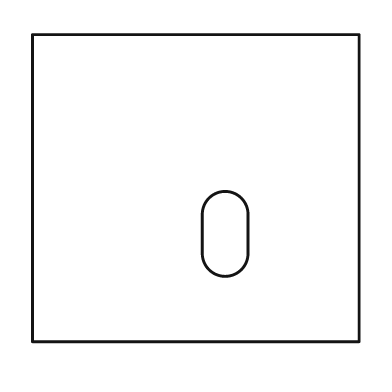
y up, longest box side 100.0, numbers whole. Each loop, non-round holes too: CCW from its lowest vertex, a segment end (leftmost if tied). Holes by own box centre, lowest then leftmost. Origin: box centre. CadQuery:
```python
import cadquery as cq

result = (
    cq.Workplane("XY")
    .moveTo(-50.0, -47.0)
    .lineTo(50.0, -47.0)
    .lineTo(50.0, 47.0)
    .lineTo(-50.0, 47.0)
    .close()
    .moveTo(2.0, -20.0)
    .threePointArc((9.0, -27.0), (16.0, -20.0))
    .lineTo(16.0, -8.0)
    .threePointArc((9.0, -1.0), (2.0, -8.0))
    .close()
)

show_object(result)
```